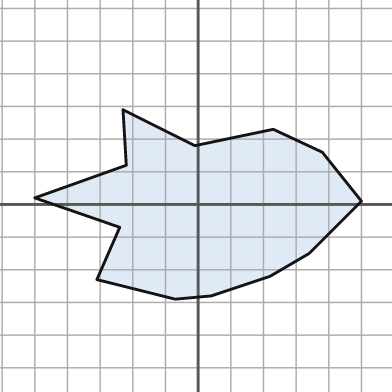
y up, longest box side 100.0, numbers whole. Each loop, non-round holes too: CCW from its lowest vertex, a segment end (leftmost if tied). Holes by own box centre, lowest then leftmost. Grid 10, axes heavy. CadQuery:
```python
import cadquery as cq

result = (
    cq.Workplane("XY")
    .moveTo(-7.0, -29.0)
    .lineTo(4.0, -28.0)
    .lineTo(22.0, -22.0)
    .lineTo(34.0, -15.0)
    .lineTo(50.0, 1.0)
    .lineTo(38.0, 16.0)
    .lineTo(23.0, 23.0)
    .lineTo(-1.0, 18.0)
    .lineTo(-23.0, 29.0)
    .lineTo(-22.0, 12.0)
    .lineTo(-50.0, 2.0)
    .lineTo(-24.0, -7.0)
    .lineTo(-31.0, -23.0)
    .close()
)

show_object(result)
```